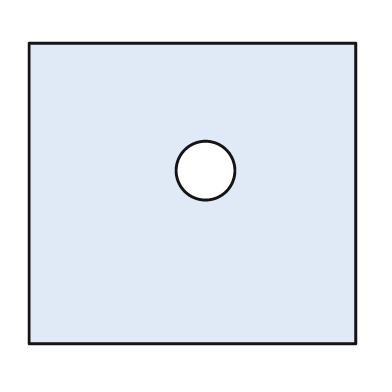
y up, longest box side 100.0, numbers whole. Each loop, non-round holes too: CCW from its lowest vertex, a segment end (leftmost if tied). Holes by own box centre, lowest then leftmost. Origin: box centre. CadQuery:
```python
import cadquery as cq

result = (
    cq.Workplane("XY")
    .moveTo(-50.0, -46.0)
    .lineTo(50.0, -46.0)
    .lineTo(50.0, 46.0)
    .lineTo(-50.0, 46.0)
    .close()
    .moveTo(4.0, 7.0)
    .circle(9.0)
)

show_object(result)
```